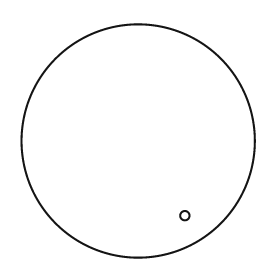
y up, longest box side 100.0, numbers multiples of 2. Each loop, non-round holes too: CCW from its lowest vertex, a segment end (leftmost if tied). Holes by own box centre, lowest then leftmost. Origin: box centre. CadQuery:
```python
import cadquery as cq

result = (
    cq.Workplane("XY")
    .moveTo(0.0, 0.0)
    .circle(50.0)
    .moveTo(20.0, -32.0)
    .circle(2.0)
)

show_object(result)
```